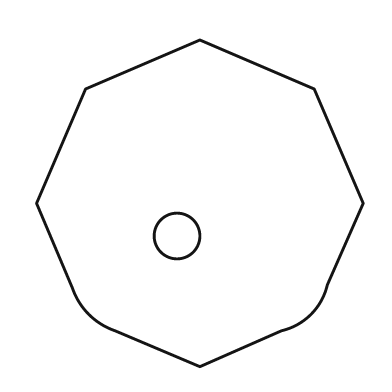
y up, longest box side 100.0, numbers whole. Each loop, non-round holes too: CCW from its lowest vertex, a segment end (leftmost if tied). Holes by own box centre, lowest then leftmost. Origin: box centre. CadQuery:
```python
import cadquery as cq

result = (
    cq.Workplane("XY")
    .moveTo(0.0, -50.0)
    .lineTo(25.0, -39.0)
    .threePointArc((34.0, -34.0), (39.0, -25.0))
    .lineTo(50.0, 0.0)
    .lineTo(35.0, 35.0)
    .lineTo(0.0, 50.0)
    .lineTo(-35.0, 35.0)
    .lineTo(-50.0, 0.0)
    .lineTo(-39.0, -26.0)
    .threePointArc((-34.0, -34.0), (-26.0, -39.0))
    .close()
    .moveTo(-7.0, -10.0)
    .circle(7.0)
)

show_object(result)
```